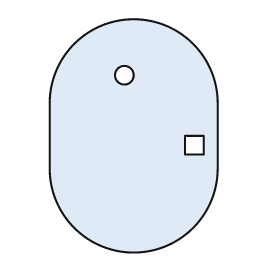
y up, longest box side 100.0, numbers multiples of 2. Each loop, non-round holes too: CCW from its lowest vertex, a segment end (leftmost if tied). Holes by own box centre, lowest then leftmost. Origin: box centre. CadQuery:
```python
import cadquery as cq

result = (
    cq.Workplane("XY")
    .moveTo(-36.0, -14.0)
    .threePointArc((0.0, -50.0), (36.0, -14.0))
    .lineTo(36.0, 14.0)
    .threePointArc((0.0, 50.0), (-36.0, 14.0))
    .close()
    .moveTo(22.0, -8.0)
    .lineTo(30.0, -8.0)
    .lineTo(30.0, 0.0)
    .lineTo(22.0, 0.0)
    .close()
    .moveTo(-4.0, 26.0)
    .circle(4.0)
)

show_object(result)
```